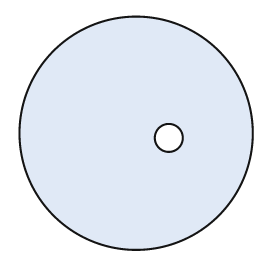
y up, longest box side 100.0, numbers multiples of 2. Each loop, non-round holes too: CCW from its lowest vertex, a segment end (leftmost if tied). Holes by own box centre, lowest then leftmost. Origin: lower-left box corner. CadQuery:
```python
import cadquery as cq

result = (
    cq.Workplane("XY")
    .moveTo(50.0, 50.0)
    .circle(50.0)
    .moveTo(64.0, 48.0)
    .circle(6.0)
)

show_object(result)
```